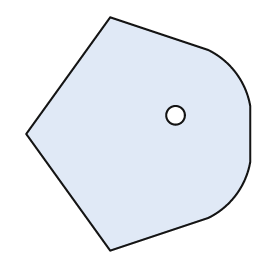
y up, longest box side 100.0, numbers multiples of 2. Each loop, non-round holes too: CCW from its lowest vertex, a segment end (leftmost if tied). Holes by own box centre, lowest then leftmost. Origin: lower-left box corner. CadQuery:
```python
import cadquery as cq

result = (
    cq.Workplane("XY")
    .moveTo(36.0, 0.0)
    .lineTo(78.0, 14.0)
    .threePointArc((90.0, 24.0), (96.0, 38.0))
    .lineTo(96.0, 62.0)
    .threePointArc((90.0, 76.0), (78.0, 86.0))
    .lineTo(36.0, 100.0)
    .lineTo(0.0, 50.0)
    .close()
    .moveTo(64.0, 58.0)
    .circle(4.0)
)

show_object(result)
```